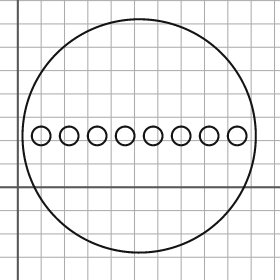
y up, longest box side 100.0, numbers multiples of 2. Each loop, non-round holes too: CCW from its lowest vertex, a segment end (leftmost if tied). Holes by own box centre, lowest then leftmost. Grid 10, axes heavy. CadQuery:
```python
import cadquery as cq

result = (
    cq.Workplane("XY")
    .moveTo(52.0, 22.0)
    .circle(50.0)
    .moveTo(10.0, 22.0)
    .circle(4.0)
    .moveTo(22.0, 22.0)
    .circle(4.0)
    .moveTo(34.0, 22.0)
    .circle(4.0)
    .moveTo(46.0, 22.0)
    .circle(4.0)
    .moveTo(58.0, 22.0)
    .circle(4.0)
    .moveTo(70.0, 22.0)
    .circle(4.0)
    .moveTo(82.0, 22.0)
    .circle(4.0)
    .moveTo(94.0, 22.0)
    .circle(4.0)
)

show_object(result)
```